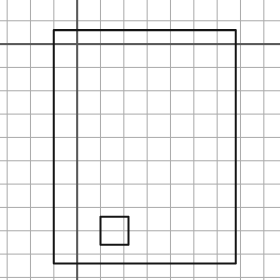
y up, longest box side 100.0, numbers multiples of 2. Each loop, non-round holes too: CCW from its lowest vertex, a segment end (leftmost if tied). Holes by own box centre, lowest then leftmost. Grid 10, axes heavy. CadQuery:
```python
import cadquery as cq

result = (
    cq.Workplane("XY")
    .moveTo(-10.0, -94.0)
    .lineTo(68.0, -94.0)
    .lineTo(68.0, 6.0)
    .lineTo(-10.0, 6.0)
    .close()
    .moveTo(10.0, -86.0)
    .lineTo(22.0, -86.0)
    .lineTo(22.0, -74.0)
    .lineTo(10.0, -74.0)
    .close()
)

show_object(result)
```